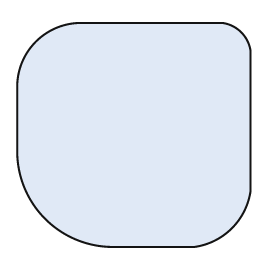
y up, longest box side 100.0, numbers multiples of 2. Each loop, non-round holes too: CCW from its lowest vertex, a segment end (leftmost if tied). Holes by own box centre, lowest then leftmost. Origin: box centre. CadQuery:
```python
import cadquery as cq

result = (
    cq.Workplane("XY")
    .moveTo(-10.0, -48.0)
    .lineTo(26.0, -48.0)
    .threePointArc((42.0, -40.0), (50.0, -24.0))
    .lineTo(50.0, 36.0)
    .threePointArc((46.0, 44.0), (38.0, 48.0))
    .lineTo(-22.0, 48.0)
    .threePointArc((-42.0, 40.0), (-50.0, 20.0))
    .lineTo(-50.0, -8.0)
    .threePointArc((-38.0, -36.0), (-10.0, -48.0))
    .close()
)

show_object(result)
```